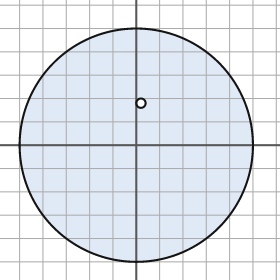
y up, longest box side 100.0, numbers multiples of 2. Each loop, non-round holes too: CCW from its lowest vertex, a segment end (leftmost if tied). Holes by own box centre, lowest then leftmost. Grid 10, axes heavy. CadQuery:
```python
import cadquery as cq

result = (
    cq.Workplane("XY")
    .moveTo(0.0, 0.0)
    .circle(50.0)
    .moveTo(2.0, 18.0)
    .circle(2.0)
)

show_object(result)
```